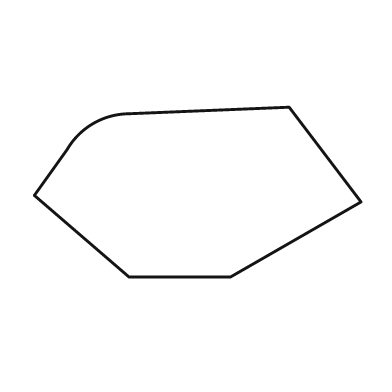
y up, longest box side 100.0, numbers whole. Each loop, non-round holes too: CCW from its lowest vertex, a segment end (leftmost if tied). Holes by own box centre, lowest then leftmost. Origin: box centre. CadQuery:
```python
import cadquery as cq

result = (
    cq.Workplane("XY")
    .moveTo(-21.0, -26.0)
    .lineTo(10.0, -26.0)
    .lineTo(50.0, -3.0)
    .lineTo(28.0, 26.0)
    .lineTo(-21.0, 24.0)
    .threePointArc((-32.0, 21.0), (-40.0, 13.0))
    .lineTo(-50.0, -1.0)
    .close()
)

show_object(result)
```